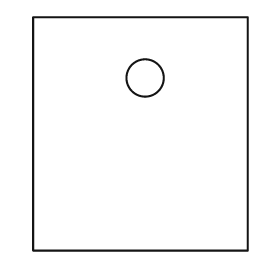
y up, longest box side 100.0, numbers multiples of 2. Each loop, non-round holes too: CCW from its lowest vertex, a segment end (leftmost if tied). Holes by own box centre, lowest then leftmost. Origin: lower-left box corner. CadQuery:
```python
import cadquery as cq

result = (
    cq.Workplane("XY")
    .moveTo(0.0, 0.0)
    .lineTo(92.0, 0.0)
    .lineTo(92.0, 100.0)
    .lineTo(0.0, 100.0)
    .close()
    .moveTo(48.0, 74.0)
    .circle(8.0)
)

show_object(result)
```